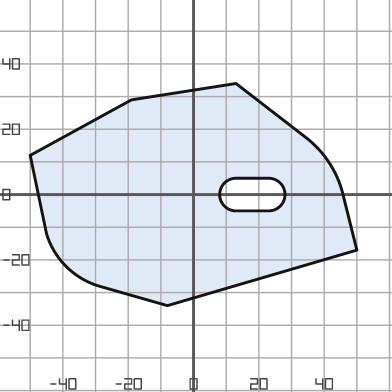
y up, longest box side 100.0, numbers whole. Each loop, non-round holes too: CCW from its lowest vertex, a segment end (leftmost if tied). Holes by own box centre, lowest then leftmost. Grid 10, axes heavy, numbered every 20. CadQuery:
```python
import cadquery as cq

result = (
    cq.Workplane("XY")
    .moveTo(-8.0, -34.0)
    .lineTo(50.0, -17.0)
    .lineTo(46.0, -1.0)
    .threePointArc((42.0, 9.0), (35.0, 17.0))
    .lineTo(13.0, 34.0)
    .lineTo(-19.0, 29.0)
    .lineTo(-50.0, 12.0)
    .lineTo(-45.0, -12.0)
    .threePointArc((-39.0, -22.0), (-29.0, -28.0))
    .close()
    .moveTo(13.0, -5.0)
    .lineTo(23.0, -5.0)
    .threePointArc((28.0, 0.0), (23.0, 5.0))
    .lineTo(13.0, 5.0)
    .threePointArc((8.0, 0.0), (13.0, -5.0))
    .close()
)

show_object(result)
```